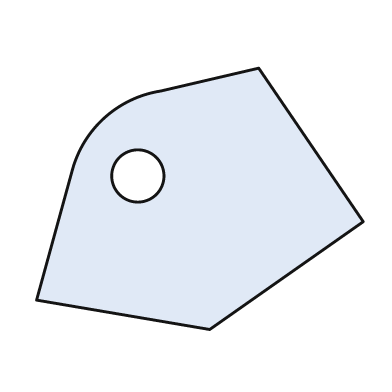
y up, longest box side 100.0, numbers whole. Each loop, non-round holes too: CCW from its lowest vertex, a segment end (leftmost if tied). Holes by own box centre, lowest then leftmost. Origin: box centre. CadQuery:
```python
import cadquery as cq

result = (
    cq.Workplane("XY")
    .moveTo(3.0, -40.0)
    .lineTo(50.0, -7.0)
    .lineTo(18.0, 40.0)
    .lineTo(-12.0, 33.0)
    .threePointArc((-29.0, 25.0), (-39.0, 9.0))
    .lineTo(-50.0, -31.0)
    .close()
    .moveTo(-19.0, 7.0)
    .circle(8.0)
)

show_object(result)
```